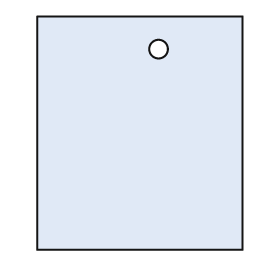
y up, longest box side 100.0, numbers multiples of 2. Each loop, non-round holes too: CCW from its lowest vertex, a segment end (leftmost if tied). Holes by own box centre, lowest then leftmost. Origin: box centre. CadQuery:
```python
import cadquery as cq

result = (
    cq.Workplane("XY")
    .moveTo(-44.0, -50.0)
    .lineTo(44.0, -50.0)
    .lineTo(44.0, 50.0)
    .lineTo(-44.0, 50.0)
    .close()
    .moveTo(8.0, 36.0)
    .circle(4.0)
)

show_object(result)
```